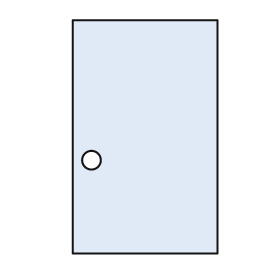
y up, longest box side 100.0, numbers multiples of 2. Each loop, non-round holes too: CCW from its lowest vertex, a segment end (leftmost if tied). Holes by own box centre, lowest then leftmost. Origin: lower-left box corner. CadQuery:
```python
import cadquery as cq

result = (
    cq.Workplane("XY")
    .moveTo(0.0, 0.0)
    .lineTo(62.0, 0.0)
    .lineTo(62.0, 100.0)
    .lineTo(0.0, 100.0)
    .close()
    .moveTo(8.0, 40.0)
    .circle(4.0)
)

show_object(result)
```